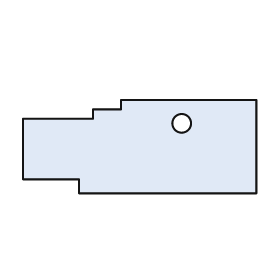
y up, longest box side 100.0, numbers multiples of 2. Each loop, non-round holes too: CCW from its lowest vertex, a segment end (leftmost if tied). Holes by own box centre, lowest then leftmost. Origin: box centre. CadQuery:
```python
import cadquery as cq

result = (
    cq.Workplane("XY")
    .moveTo(-26.0, -20.0)
    .lineTo(50.0, -20.0)
    .lineTo(50.0, 20.0)
    .lineTo(-8.0, 20.0)
    .lineTo(-8.0, 16.0)
    .lineTo(-20.0, 16.0)
    .lineTo(-20.0, 12.0)
    .lineTo(-50.0, 12.0)
    .lineTo(-50.0, -14.0)
    .lineTo(-26.0, -14.0)
    .close()
    .moveTo(18.0, 10.0)
    .circle(4.0)
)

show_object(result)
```